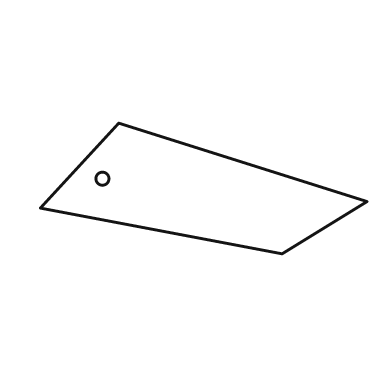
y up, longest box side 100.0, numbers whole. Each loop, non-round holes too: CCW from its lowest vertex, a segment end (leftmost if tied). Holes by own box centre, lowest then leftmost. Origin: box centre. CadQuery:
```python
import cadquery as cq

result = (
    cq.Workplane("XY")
    .moveTo(24.0, -20.0)
    .lineTo(50.0, -4.0)
    .lineTo(-26.0, 20.0)
    .lineTo(-50.0, -6.0)
    .close()
    .moveTo(-31.0, 3.0)
    .circle(2.0)
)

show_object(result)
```